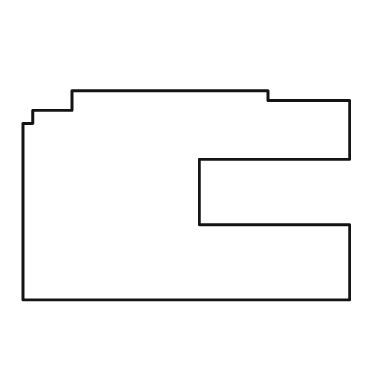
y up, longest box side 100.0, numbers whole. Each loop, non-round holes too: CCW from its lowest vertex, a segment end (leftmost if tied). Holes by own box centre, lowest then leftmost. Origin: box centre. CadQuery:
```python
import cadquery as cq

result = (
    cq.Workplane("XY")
    .moveTo(-50.0, -32.0)
    .lineTo(50.0, -32.0)
    .lineTo(50.0, -9.0)
    .lineTo(4.0, -9.0)
    .lineTo(4.0, 11.0)
    .lineTo(50.0, 11.0)
    .lineTo(50.0, 29.0)
    .lineTo(25.0, 29.0)
    .lineTo(25.0, 32.0)
    .lineTo(-35.0, 32.0)
    .lineTo(-35.0, 26.0)
    .lineTo(-47.0, 26.0)
    .lineTo(-47.0, 22.0)
    .lineTo(-50.0, 22.0)
    .close()
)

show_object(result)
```